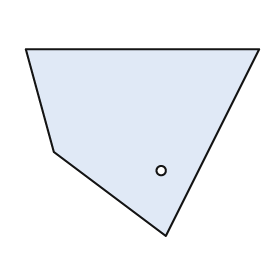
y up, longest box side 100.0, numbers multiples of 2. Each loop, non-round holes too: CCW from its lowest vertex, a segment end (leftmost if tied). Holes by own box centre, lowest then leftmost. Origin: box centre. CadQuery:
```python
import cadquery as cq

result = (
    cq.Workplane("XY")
    .moveTo(10.0, -40.0)
    .lineTo(50.0, 40.0)
    .lineTo(-50.0, 40.0)
    .lineTo(-38.0, -4.0)
    .close()
    .moveTo(8.0, -12.0)
    .circle(2.0)
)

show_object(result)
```